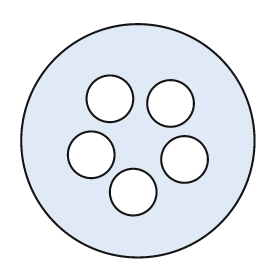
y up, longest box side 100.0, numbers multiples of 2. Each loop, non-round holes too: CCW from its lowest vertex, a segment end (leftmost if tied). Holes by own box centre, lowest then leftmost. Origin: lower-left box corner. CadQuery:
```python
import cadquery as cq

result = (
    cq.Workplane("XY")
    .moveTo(50.0, 50.0)
    .circle(50.0)
    .moveTo(48.0, 28.0)
    .circle(10.0)
    .moveTo(70.0, 42.0)
    .circle(10.0)
    .moveTo(30.0, 44.0)
    .circle(10.0)
    .moveTo(64.0, 66.0)
    .circle(10.0)
    .moveTo(38.0, 68.0)
    .circle(10.0)
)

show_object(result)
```